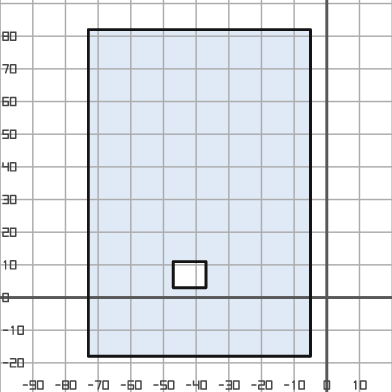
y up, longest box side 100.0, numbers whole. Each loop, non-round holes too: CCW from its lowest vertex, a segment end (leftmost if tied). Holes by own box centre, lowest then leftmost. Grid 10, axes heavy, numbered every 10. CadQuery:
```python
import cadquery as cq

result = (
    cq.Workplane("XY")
    .moveTo(-73.0, -18.0)
    .lineTo(-5.0, -18.0)
    .lineTo(-5.0, 82.0)
    .lineTo(-73.0, 82.0)
    .close()
    .moveTo(-47.0, 3.0)
    .lineTo(-37.0, 3.0)
    .lineTo(-37.0, 11.0)
    .lineTo(-47.0, 11.0)
    .close()
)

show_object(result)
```